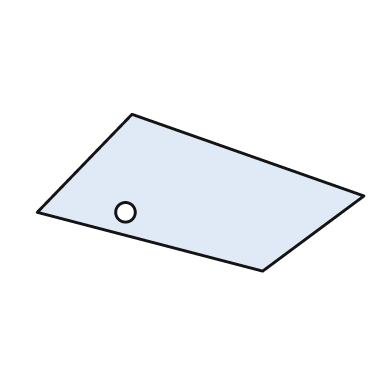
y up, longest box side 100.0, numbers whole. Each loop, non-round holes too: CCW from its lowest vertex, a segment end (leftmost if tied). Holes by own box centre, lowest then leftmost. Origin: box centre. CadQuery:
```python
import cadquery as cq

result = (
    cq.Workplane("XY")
    .moveTo(19.0, -24.0)
    .lineTo(50.0, -1.0)
    .lineTo(-21.0, 24.0)
    .lineTo(-50.0, -6.0)
    .close()
    .moveTo(-23.0, -6.0)
    .circle(3.0)
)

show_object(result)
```